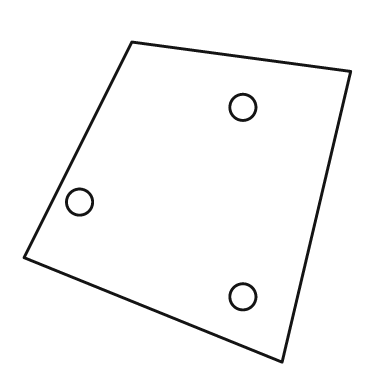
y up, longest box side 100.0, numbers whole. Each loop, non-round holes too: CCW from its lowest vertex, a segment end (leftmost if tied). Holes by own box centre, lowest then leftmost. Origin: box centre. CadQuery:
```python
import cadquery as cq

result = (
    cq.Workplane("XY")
    .moveTo(29.0, -49.0)
    .lineTo(50.0, 40.0)
    .lineTo(-17.0, 49.0)
    .lineTo(-50.0, -17.0)
    .close()
    .moveTo(17.0, -29.0)
    .circle(4.0)
    .moveTo(-33.0, 0.0)
    .circle(4.0)
    .moveTo(17.0, 29.0)
    .circle(4.0)
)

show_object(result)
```